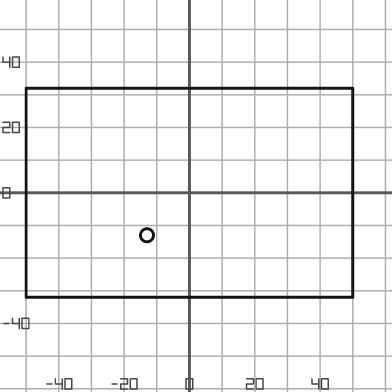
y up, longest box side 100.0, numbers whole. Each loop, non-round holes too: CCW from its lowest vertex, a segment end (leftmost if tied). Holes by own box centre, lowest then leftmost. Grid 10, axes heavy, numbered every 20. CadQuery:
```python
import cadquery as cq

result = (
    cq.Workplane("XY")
    .moveTo(-50.0, -32.0)
    .lineTo(50.0, -32.0)
    .lineTo(50.0, 32.0)
    .lineTo(-50.0, 32.0)
    .close()
    .moveTo(-13.0, -13.0)
    .circle(2.0)
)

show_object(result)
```